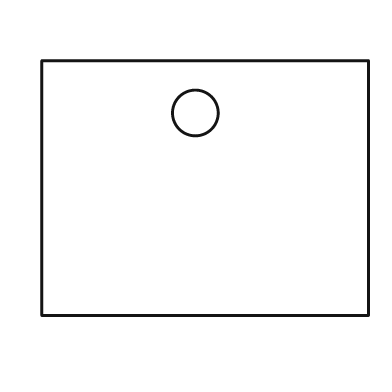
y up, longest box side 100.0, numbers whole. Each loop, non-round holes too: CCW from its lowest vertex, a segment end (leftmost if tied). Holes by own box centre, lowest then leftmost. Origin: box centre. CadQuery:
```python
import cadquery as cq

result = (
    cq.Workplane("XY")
    .moveTo(-50.0, -39.0)
    .lineTo(50.0, -39.0)
    .lineTo(50.0, 39.0)
    .lineTo(-50.0, 39.0)
    .close()
    .moveTo(-3.0, 23.0)
    .circle(7.0)
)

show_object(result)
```